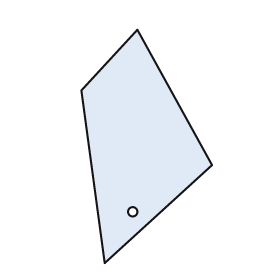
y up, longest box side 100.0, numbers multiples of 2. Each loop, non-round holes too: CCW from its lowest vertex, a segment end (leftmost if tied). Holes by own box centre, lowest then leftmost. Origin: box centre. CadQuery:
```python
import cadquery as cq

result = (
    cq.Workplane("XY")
    .moveTo(-18.0, -50.0)
    .lineTo(28.0, -8.0)
    .lineTo(-4.0, 50.0)
    .lineTo(-28.0, 24.0)
    .close()
    .moveTo(-6.0, -28.0)
    .circle(2.0)
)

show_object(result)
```